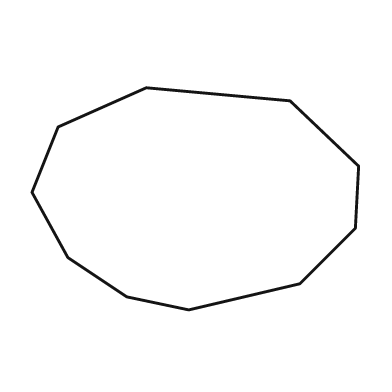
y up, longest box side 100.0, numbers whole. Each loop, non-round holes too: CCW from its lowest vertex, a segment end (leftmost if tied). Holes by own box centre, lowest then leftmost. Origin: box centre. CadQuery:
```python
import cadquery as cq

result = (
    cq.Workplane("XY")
    .moveTo(-2.0, -34.0)
    .lineTo(32.0, -26.0)
    .lineTo(49.0, -9.0)
    .lineTo(50.0, 10.0)
    .lineTo(29.0, 30.0)
    .lineTo(-15.0, 34.0)
    .lineTo(-42.0, 22.0)
    .lineTo(-50.0, 2.0)
    .lineTo(-39.0, -18.0)
    .lineTo(-21.0, -30.0)
    .close()
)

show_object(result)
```